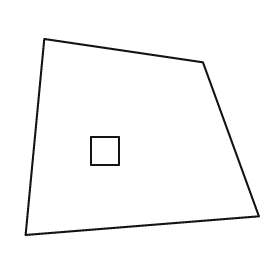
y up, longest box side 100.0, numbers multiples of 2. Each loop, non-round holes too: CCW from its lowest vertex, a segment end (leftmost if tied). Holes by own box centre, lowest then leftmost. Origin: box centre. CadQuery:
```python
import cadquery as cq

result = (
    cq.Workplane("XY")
    .moveTo(-50.0, -42.0)
    .lineTo(50.0, -34.0)
    .lineTo(26.0, 32.0)
    .lineTo(-42.0, 42.0)
    .close()
    .moveTo(-22.0, -12.0)
    .lineTo(-10.0, -12.0)
    .lineTo(-10.0, 0.0)
    .lineTo(-22.0, 0.0)
    .close()
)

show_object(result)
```